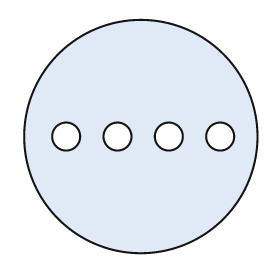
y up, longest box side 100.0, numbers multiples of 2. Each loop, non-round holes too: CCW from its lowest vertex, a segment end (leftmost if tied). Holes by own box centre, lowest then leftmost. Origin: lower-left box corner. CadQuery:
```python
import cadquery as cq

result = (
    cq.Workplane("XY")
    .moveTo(50.0, 50.0)
    .circle(50.0)
    .moveTo(18.0, 50.0)
    .circle(6.0)
    .moveTo(40.0, 50.0)
    .circle(6.0)
    .moveTo(62.0, 50.0)
    .circle(6.0)
    .moveTo(84.0, 50.0)
    .circle(6.0)
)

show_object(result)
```